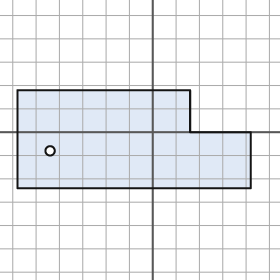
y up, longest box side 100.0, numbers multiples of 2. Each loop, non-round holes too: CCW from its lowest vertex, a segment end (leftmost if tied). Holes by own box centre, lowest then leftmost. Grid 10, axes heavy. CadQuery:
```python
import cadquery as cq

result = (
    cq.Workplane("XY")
    .moveTo(-58.0, -24.0)
    .lineTo(42.0, -24.0)
    .lineTo(42.0, 0.0)
    .lineTo(16.0, 0.0)
    .lineTo(16.0, 18.0)
    .lineTo(-58.0, 18.0)
    .close()
    .moveTo(-44.0, -8.0)
    .circle(2.0)
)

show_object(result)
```